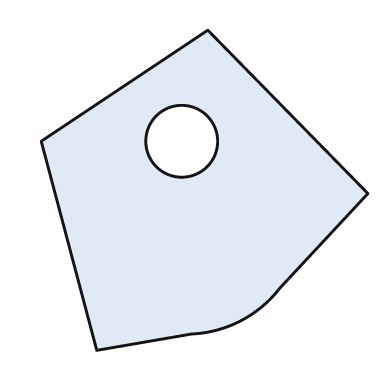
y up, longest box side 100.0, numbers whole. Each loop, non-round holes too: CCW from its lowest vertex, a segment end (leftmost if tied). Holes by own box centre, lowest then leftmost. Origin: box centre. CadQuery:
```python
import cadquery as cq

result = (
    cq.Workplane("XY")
    .moveTo(-33.0, -49.0)
    .lineTo(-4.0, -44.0)
    .threePointArc((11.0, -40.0), (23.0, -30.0))
    .lineTo(50.0, -1.0)
    .lineTo(1.0, 49.0)
    .lineTo(-50.0, 15.0)
    .close()
    .moveTo(-7.0, 15.0)
    .circle(11.0)
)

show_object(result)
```